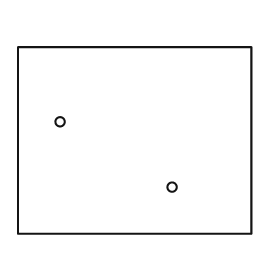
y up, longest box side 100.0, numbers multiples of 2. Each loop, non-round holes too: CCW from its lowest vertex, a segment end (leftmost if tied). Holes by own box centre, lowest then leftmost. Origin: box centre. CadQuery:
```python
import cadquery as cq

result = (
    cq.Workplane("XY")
    .moveTo(-50.0, -40.0)
    .lineTo(50.0, -40.0)
    .lineTo(50.0, 40.0)
    .lineTo(-50.0, 40.0)
    .close()
    .moveTo(16.0, -20.0)
    .circle(2.0)
    .moveTo(-32.0, 8.0)
    .circle(2.0)
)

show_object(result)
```